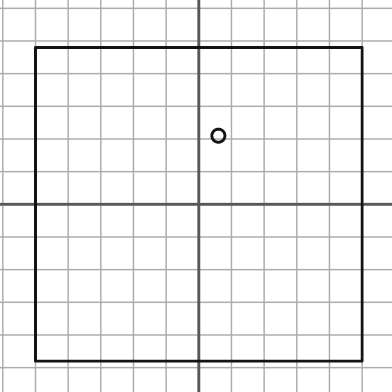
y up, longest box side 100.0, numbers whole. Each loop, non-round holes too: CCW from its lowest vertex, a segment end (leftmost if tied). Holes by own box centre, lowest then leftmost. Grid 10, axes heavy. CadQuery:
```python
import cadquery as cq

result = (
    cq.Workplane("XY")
    .moveTo(-50.0, -48.0)
    .lineTo(50.0, -48.0)
    .lineTo(50.0, 48.0)
    .lineTo(-50.0, 48.0)
    .close()
    .moveTo(6.0, 21.0)
    .circle(2.0)
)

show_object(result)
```